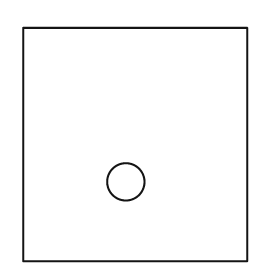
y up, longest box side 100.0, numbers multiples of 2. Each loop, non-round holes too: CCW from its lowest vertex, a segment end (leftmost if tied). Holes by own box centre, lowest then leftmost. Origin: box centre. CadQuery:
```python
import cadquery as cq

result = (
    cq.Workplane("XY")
    .moveTo(-48.0, -50.0)
    .lineTo(48.0, -50.0)
    .lineTo(48.0, 50.0)
    .lineTo(-48.0, 50.0)
    .close()
    .moveTo(-4.0, -16.0)
    .circle(8.0)
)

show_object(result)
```